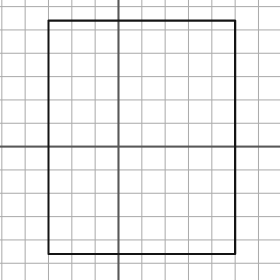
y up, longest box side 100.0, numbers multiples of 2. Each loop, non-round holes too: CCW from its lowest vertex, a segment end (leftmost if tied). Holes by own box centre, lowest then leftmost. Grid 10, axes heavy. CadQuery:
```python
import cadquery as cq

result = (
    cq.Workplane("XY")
    .moveTo(-30.0, -46.0)
    .lineTo(50.0, -46.0)
    .lineTo(50.0, 54.0)
    .lineTo(-30.0, 54.0)
    .close()
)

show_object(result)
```